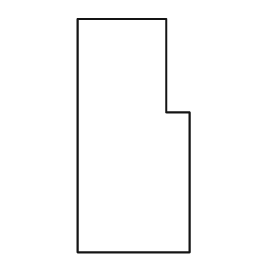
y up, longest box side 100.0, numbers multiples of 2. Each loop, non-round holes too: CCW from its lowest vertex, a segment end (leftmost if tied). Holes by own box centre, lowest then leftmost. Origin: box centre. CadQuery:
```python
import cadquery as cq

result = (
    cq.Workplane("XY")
    .moveTo(-24.0, -50.0)
    .lineTo(24.0, -50.0)
    .lineTo(24.0, 10.0)
    .lineTo(14.0, 10.0)
    .lineTo(14.0, 50.0)
    .lineTo(-24.0, 50.0)
    .close()
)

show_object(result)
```